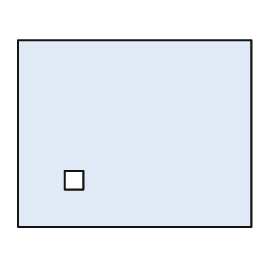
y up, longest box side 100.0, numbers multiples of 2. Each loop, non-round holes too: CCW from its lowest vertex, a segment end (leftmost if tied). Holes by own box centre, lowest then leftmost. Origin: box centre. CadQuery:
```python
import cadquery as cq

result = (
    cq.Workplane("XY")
    .moveTo(-50.0, -40.0)
    .lineTo(50.0, -40.0)
    .lineTo(50.0, 40.0)
    .lineTo(-50.0, 40.0)
    .close()
    .moveTo(-30.0, -24.0)
    .lineTo(-22.0, -24.0)
    .lineTo(-22.0, -16.0)
    .lineTo(-30.0, -16.0)
    .close()
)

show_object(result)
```